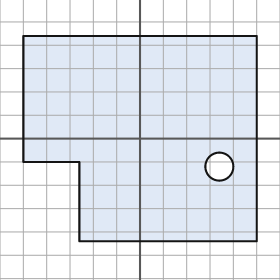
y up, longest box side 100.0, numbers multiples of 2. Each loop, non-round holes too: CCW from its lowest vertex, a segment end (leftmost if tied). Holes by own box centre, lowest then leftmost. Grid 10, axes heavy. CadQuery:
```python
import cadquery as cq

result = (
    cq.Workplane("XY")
    .moveTo(-26.0, -44.0)
    .lineTo(50.0, -44.0)
    .lineTo(50.0, 44.0)
    .lineTo(-50.0, 44.0)
    .lineTo(-50.0, -10.0)
    .lineTo(-26.0, -10.0)
    .close()
    .moveTo(34.0, -12.0)
    .circle(6.0)
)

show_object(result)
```